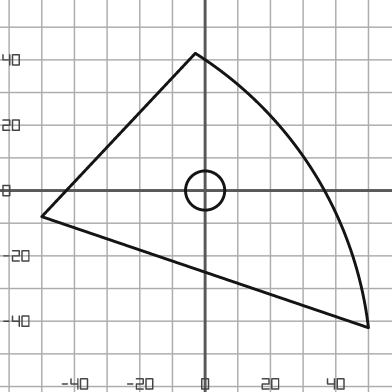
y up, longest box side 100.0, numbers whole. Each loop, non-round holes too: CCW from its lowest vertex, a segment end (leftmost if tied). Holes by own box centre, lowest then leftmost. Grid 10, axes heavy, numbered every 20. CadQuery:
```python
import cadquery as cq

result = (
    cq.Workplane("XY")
    .moveTo(50.0, -42.0)
    .threePointArc((33.0, 6.0), (-3.0, 42.0))
    .lineTo(-50.0, -8.0)
    .close()
    .moveTo(0.0, 0.0)
    .circle(6.0)
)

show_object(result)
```